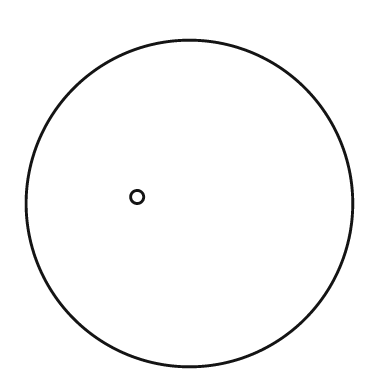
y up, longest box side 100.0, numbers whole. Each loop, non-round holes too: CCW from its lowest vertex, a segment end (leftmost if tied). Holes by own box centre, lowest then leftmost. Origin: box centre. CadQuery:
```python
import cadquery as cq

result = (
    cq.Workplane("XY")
    .moveTo(0.0, 0.0)
    .circle(50.0)
    .moveTo(-16.0, 2.0)
    .circle(2.0)
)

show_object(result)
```